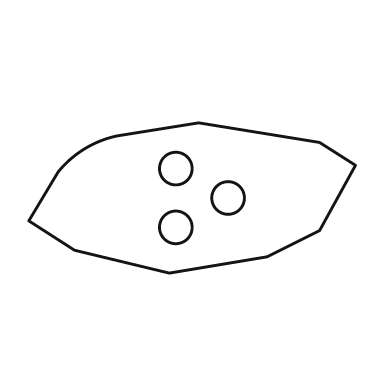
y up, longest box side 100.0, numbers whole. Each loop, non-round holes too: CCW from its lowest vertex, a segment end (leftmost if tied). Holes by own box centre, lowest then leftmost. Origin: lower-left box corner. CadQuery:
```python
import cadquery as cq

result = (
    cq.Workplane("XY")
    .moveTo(43.0, 0.0)
    .lineTo(73.0, 5.0)
    .lineTo(89.0, 13.0)
    .lineTo(100.0, 33.0)
    .lineTo(89.0, 40.0)
    .lineTo(52.0, 46.0)
    .lineTo(27.0, 42.0)
    .threePointArc((17.0, 38.0), (9.0, 31.0))
    .lineTo(0.0, 16.0)
    .lineTo(14.0, 7.0)
    .close()
    .moveTo(45.0, 14.0)
    .circle(5.0)
    .moveTo(61.0, 23.0)
    .circle(5.0)
    .moveTo(45.0, 32.0)
    .circle(5.0)
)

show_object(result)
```